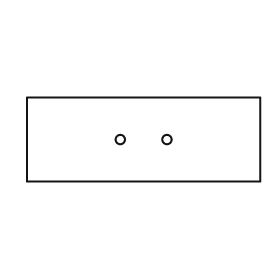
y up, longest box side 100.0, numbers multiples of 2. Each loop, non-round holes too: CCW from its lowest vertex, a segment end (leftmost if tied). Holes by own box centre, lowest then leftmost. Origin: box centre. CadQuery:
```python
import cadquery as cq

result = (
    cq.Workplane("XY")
    .moveTo(-50.0, -18.0)
    .lineTo(50.0, -18.0)
    .lineTo(50.0, 18.0)
    .lineTo(-50.0, 18.0)
    .close()
    .moveTo(-10.0, 0.0)
    .circle(2.0)
    .moveTo(10.0, 0.0)
    .circle(2.0)
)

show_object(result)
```